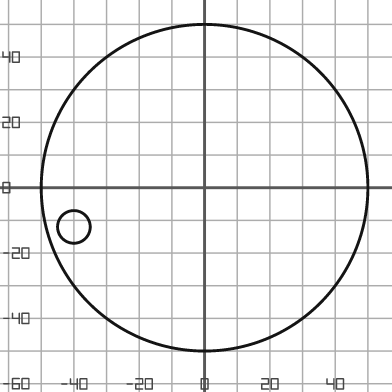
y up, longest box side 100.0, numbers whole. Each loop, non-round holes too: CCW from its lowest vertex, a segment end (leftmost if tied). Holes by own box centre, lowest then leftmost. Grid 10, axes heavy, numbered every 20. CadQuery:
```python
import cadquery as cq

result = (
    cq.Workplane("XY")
    .moveTo(0.0, 0.0)
    .circle(50.0)
    .moveTo(-40.0, -12.0)
    .circle(5.0)
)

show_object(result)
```